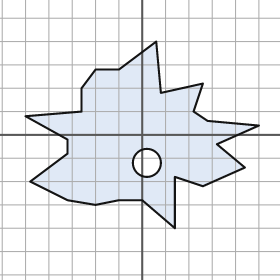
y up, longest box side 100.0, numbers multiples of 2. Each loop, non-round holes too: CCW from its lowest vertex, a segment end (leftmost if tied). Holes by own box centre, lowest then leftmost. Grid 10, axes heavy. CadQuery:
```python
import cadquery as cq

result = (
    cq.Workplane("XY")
    .moveTo(14.0, -40.0)
    .lineTo(14.0, -18.0)
    .lineTo(26.0, -22.0)
    .lineTo(44.0, -14.0)
    .lineTo(32.0, -4.0)
    .lineTo(50.0, 4.0)
    .lineTo(28.0, 6.0)
    .lineTo(22.0, 10.0)
    .lineTo(26.0, 22.0)
    .lineTo(8.0, 18.0)
    .lineTo(6.0, 40.0)
    .lineTo(-10.0, 28.0)
    .lineTo(-20.0, 28.0)
    .lineTo(-26.0, 20.0)
    .lineTo(-26.0, 10.0)
    .lineTo(-50.0, 8.0)
    .lineTo(-32.0, -2.0)
    .lineTo(-32.0, -8.0)
    .lineTo(-48.0, -20.0)
    .lineTo(-32.0, -28.0)
    .lineTo(-20.0, -30.0)
    .lineTo(-10.0, -28.0)
    .lineTo(0.0, -28.0)
    .close()
    .moveTo(2.0, -12.0)
    .circle(6.0)
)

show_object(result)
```